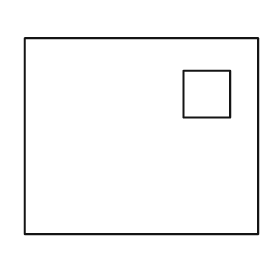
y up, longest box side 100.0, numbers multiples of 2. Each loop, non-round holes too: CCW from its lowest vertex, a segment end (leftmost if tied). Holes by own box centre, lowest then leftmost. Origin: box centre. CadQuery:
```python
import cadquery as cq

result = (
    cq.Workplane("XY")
    .moveTo(-50.0, -42.0)
    .lineTo(50.0, -42.0)
    .lineTo(50.0, 42.0)
    .lineTo(-50.0, 42.0)
    .close()
    .moveTo(18.0, 8.0)
    .lineTo(38.0, 8.0)
    .lineTo(38.0, 28.0)
    .lineTo(18.0, 28.0)
    .close()
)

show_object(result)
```